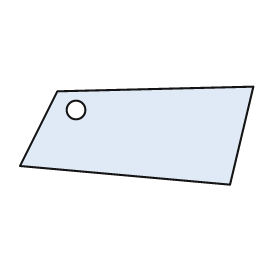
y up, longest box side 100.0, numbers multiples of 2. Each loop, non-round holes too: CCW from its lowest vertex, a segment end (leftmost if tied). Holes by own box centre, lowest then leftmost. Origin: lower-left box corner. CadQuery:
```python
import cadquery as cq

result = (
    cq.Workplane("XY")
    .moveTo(90.0, 0.0)
    .lineTo(100.0, 42.0)
    .lineTo(16.0, 40.0)
    .lineTo(0.0, 8.0)
    .close()
    .moveTo(24.0, 32.0)
    .circle(4.0)
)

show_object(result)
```